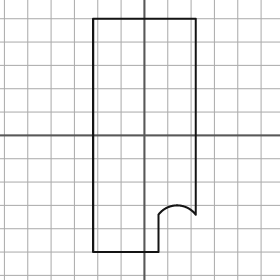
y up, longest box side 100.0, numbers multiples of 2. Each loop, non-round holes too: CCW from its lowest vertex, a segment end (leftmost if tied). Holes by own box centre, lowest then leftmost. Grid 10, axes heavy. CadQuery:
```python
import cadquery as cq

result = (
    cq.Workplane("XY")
    .moveTo(-22.0, -50.0)
    .lineTo(6.0, -50.0)
    .lineTo(6.0, -34.0)
    .threePointArc((14.0, -30.0), (22.0, -34.0))
    .lineTo(22.0, 50.0)
    .lineTo(-22.0, 50.0)
    .close()
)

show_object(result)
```